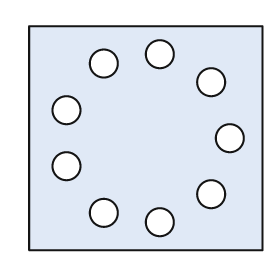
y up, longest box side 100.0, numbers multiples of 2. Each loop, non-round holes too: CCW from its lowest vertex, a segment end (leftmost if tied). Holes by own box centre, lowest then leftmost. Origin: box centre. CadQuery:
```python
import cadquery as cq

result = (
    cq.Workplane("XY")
    .moveTo(-50.0, -48.0)
    .lineTo(50.0, -48.0)
    .lineTo(50.0, 48.0)
    .lineTo(-50.0, 48.0)
    .close()
    .moveTo(6.0, -36.0)
    .circle(6.0)
    .moveTo(-18.0, -32.0)
    .circle(6.0)
    .moveTo(28.0, -24.0)
    .circle(6.0)
    .moveTo(-34.0, -12.0)
    .circle(6.0)
    .moveTo(36.0, 0.0)
    .circle(6.0)
    .moveTo(-34.0, 12.0)
    .circle(6.0)
    .moveTo(28.0, 24.0)
    .circle(6.0)
    .moveTo(-18.0, 32.0)
    .circle(6.0)
    .moveTo(6.0, 36.0)
    .circle(6.0)
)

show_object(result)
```